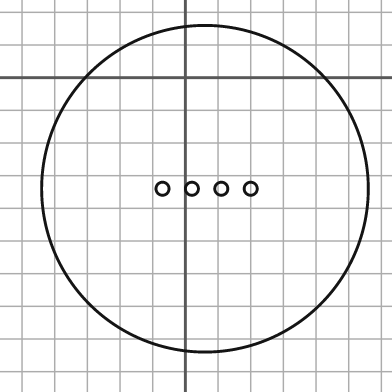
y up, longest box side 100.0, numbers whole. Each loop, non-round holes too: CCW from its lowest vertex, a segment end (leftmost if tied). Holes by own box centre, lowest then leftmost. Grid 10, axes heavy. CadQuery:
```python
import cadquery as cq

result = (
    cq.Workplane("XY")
    .moveTo(6.0, -34.0)
    .circle(50.0)
    .moveTo(-7.0, -34.0)
    .circle(2.0)
    .moveTo(2.0, -34.0)
    .circle(2.0)
    .moveTo(11.0, -34.0)
    .circle(2.0)
    .moveTo(20.0, -34.0)
    .circle(2.0)
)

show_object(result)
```